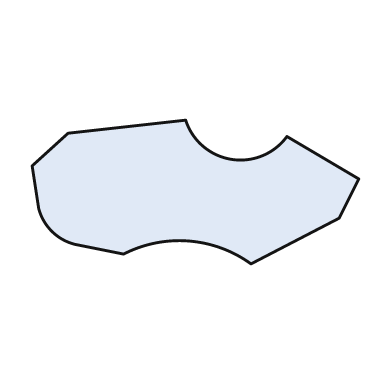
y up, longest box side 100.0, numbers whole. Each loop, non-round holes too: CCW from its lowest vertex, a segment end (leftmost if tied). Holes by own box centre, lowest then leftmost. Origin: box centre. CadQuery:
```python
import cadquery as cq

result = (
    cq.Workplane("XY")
    .moveTo(17.0, -22.0)
    .lineTo(44.0, -8.0)
    .lineTo(50.0, 4.0)
    .lineTo(28.0, 17.0)
    .threePointArc((11.0, 10.0), (-3.0, 22.0))
    .lineTo(-39.0, 18.0)
    .lineTo(-50.0, 8.0)
    .lineTo(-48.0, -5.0)
    .threePointArc((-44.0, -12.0), (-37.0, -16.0))
    .lineTo(-22.0, -19.0)
    .threePointArc((-2.0, -15.0), (17.0, -22.0))
    .close()
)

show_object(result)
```